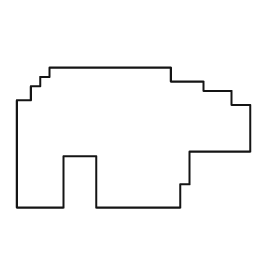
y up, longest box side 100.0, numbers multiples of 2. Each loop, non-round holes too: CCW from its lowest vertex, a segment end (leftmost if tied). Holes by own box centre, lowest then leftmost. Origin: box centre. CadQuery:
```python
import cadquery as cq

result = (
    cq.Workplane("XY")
    .moveTo(-50.0, -30.0)
    .lineTo(-30.0, -30.0)
    .lineTo(-30.0, -8.0)
    .lineTo(-16.0, -8.0)
    .lineTo(-16.0, -30.0)
    .lineTo(20.0, -30.0)
    .lineTo(20.0, -20.0)
    .lineTo(24.0, -20.0)
    .lineTo(24.0, -6.0)
    .lineTo(50.0, -6.0)
    .lineTo(50.0, 14.0)
    .lineTo(42.0, 14.0)
    .lineTo(42.0, 20.0)
    .lineTo(30.0, 20.0)
    .lineTo(30.0, 24.0)
    .lineTo(16.0, 24.0)
    .lineTo(16.0, 30.0)
    .lineTo(-36.0, 30.0)
    .lineTo(-36.0, 26.0)
    .lineTo(-40.0, 26.0)
    .lineTo(-40.0, 22.0)
    .lineTo(-44.0, 22.0)
    .lineTo(-44.0, 16.0)
    .lineTo(-50.0, 16.0)
    .close()
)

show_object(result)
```